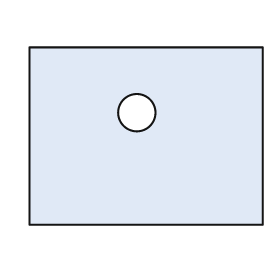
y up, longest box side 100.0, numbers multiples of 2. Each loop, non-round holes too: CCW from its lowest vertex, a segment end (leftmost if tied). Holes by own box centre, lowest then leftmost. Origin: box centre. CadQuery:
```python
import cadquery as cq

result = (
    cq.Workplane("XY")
    .moveTo(-50.0, -38.0)
    .lineTo(50.0, -38.0)
    .lineTo(50.0, 38.0)
    .lineTo(-50.0, 38.0)
    .close()
    .moveTo(-4.0, 10.0)
    .circle(8.0)
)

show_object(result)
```